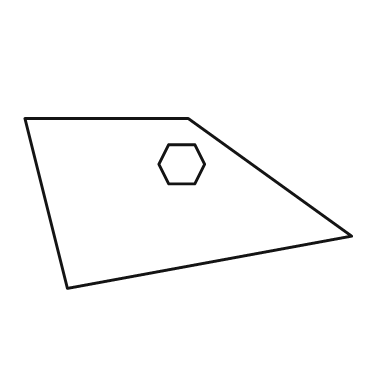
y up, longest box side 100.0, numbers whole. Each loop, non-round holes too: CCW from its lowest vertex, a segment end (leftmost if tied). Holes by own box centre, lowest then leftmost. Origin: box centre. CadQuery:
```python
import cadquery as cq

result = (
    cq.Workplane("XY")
    .moveTo(-37.0, -26.0)
    .lineTo(50.0, -10.0)
    .lineTo(0.0, 26.0)
    .lineTo(-50.0, 26.0)
    .close()
    .moveTo(-6.0, 6.0)
    .lineTo(2.0, 6.0)
    .lineTo(5.0, 12.0)
    .lineTo(2.0, 18.0)
    .lineTo(-6.0, 18.0)
    .lineTo(-9.0, 12.0)
    .close()
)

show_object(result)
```